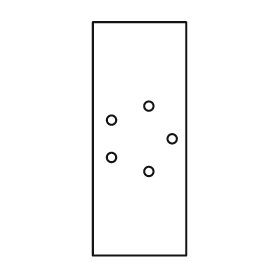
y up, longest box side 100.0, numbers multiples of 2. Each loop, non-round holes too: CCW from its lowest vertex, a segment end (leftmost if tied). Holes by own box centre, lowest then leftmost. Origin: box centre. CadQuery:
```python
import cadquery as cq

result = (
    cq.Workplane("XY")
    .moveTo(-20.0, -50.0)
    .lineTo(20.0, -50.0)
    .lineTo(20.0, 50.0)
    .lineTo(-20.0, 50.0)
    .close()
    .moveTo(4.0, -14.0)
    .circle(2.0)
    .moveTo(-12.0, -8.0)
    .circle(2.0)
    .moveTo(14.0, 0.0)
    .circle(2.0)
    .moveTo(-12.0, 8.0)
    .circle(2.0)
    .moveTo(4.0, 14.0)
    .circle(2.0)
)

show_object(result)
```